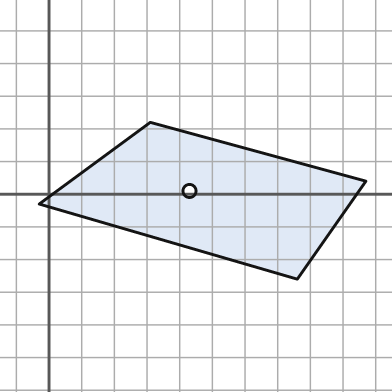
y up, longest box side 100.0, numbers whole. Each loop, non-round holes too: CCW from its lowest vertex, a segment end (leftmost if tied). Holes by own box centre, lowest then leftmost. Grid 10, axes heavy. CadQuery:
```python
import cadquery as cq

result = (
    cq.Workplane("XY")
    .moveTo(76.0, -26.0)
    .lineTo(97.0, 4.0)
    .lineTo(31.0, 22.0)
    .lineTo(-3.0, -3.0)
    .close()
    .moveTo(43.0, 1.0)
    .circle(2.0)
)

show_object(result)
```